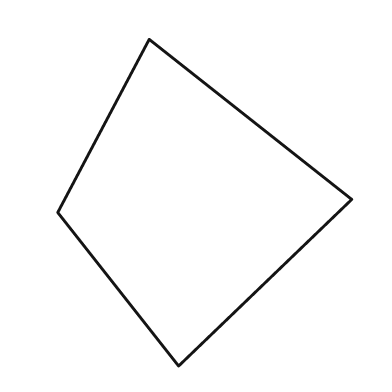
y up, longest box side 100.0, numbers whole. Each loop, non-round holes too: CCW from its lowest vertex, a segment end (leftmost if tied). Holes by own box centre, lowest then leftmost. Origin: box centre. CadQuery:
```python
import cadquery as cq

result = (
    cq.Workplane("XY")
    .moveTo(-8.0, -50.0)
    .lineTo(45.0, 1.0)
    .lineTo(-17.0, 50.0)
    .lineTo(-45.0, -3.0)
    .close()
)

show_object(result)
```